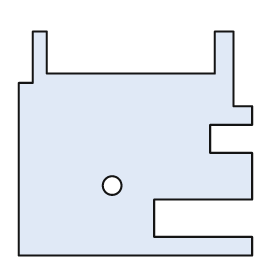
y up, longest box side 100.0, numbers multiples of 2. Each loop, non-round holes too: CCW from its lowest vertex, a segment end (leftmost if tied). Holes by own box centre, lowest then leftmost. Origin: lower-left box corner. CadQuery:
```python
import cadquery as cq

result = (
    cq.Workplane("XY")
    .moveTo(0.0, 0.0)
    .lineTo(100.0, 0.0)
    .lineTo(100.0, 8.0)
    .lineTo(58.0, 8.0)
    .lineTo(58.0, 24.0)
    .lineTo(100.0, 24.0)
    .lineTo(100.0, 44.0)
    .lineTo(82.0, 44.0)
    .lineTo(82.0, 56.0)
    .lineTo(100.0, 56.0)
    .lineTo(100.0, 64.0)
    .lineTo(92.0, 64.0)
    .lineTo(92.0, 96.0)
    .lineTo(84.0, 96.0)
    .lineTo(84.0, 78.0)
    .lineTo(12.0, 78.0)
    .lineTo(12.0, 96.0)
    .lineTo(6.0, 96.0)
    .lineTo(6.0, 74.0)
    .lineTo(0.0, 74.0)
    .close()
    .moveTo(40.0, 30.0)
    .circle(4.0)
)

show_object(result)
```